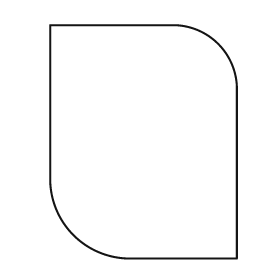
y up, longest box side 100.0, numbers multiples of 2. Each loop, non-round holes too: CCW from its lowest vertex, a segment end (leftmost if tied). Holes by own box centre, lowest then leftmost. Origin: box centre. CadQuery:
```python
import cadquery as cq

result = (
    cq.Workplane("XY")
    .moveTo(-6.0, -50.0)
    .lineTo(40.0, -50.0)
    .lineTo(40.0, 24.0)
    .threePointArc((32.0, 42.0), (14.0, 50.0))
    .lineTo(-40.0, 50.0)
    .lineTo(-40.0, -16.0)
    .threePointArc((-30.0, -40.0), (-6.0, -50.0))
    .close()
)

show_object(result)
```